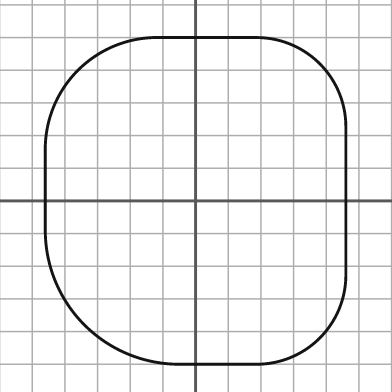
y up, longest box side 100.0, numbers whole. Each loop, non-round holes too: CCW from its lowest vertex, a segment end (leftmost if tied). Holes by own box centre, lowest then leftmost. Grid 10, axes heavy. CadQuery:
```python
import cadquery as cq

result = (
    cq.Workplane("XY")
    .moveTo(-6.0, -50.0)
    .lineTo(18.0, -50.0)
    .threePointArc((38.0, -42.0), (46.0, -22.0))
    .lineTo(46.0, 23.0)
    .threePointArc((38.0, 42.0), (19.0, 50.0))
    .lineTo(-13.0, 50.0)
    .threePointArc((-36.0, 40.0), (-46.0, 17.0))
    .lineTo(-46.0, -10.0)
    .threePointArc((-34.0, -38.0), (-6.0, -50.0))
    .close()
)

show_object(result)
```